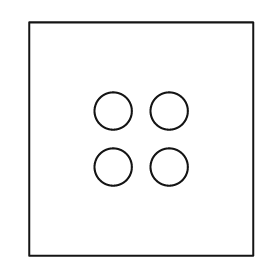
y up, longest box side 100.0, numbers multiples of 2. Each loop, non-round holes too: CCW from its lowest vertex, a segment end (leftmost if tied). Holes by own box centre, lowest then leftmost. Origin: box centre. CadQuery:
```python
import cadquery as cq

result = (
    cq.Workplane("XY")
    .moveTo(-48.0, -50.0)
    .lineTo(48.0, -50.0)
    .lineTo(48.0, 50.0)
    .lineTo(-48.0, 50.0)
    .close()
    .moveTo(-12.0, -12.0)
    .circle(8.0)
    .moveTo(12.0, -12.0)
    .circle(8.0)
    .moveTo(-12.0, 12.0)
    .circle(8.0)
    .moveTo(12.0, 12.0)
    .circle(8.0)
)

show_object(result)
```